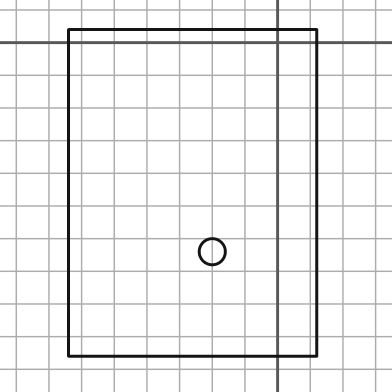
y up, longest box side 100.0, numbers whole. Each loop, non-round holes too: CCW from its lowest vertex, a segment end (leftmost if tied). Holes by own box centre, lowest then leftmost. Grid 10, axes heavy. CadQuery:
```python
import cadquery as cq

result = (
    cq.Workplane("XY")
    .moveTo(-64.0, -96.0)
    .lineTo(12.0, -96.0)
    .lineTo(12.0, 4.0)
    .lineTo(-64.0, 4.0)
    .close()
    .moveTo(-20.0, -64.0)
    .circle(4.0)
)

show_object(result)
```